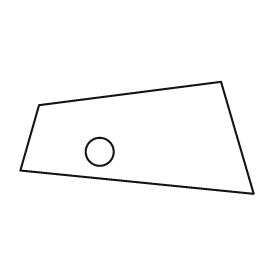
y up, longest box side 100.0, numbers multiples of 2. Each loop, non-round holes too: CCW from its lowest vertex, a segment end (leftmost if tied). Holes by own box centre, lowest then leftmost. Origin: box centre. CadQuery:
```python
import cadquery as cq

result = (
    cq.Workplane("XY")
    .moveTo(50.0, -24.0)
    .lineTo(36.0, 24.0)
    .lineTo(-42.0, 14.0)
    .lineTo(-50.0, -14.0)
    .close()
    .moveTo(-16.0, -6.0)
    .circle(6.0)
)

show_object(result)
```